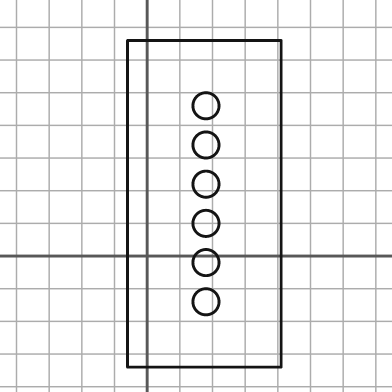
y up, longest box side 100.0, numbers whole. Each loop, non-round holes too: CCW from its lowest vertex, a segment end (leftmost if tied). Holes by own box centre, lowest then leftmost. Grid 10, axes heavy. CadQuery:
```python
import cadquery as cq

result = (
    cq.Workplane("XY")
    .moveTo(-6.0, -34.0)
    .lineTo(41.0, -34.0)
    .lineTo(41.0, 66.0)
    .lineTo(-6.0, 66.0)
    .close()
    .moveTo(18.0, -14.0)
    .circle(4.0)
    .moveTo(18.0, -2.0)
    .circle(4.0)
    .moveTo(18.0, 10.0)
    .circle(4.0)
    .moveTo(18.0, 22.0)
    .circle(4.0)
    .moveTo(18.0, 34.0)
    .circle(4.0)
    .moveTo(18.0, 46.0)
    .circle(4.0)
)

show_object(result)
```